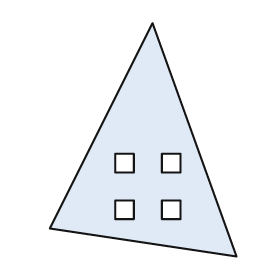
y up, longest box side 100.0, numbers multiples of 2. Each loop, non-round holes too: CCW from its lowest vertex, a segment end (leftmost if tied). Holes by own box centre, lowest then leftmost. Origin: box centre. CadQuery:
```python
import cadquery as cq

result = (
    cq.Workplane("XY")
    .moveTo(40.0, -50.0)
    .lineTo(4.0, 50.0)
    .lineTo(-40.0, -38.0)
    .close()
    .moveTo(-12.0, -34.0)
    .lineTo(-4.0, -34.0)
    .lineTo(-4.0, -26.0)
    .lineTo(-12.0, -26.0)
    .close()
    .moveTo(8.0, -34.0)
    .lineTo(16.0, -34.0)
    .lineTo(16.0, -26.0)
    .lineTo(8.0, -26.0)
    .close()
    .moveTo(-12.0, -14.0)
    .lineTo(-4.0, -14.0)
    .lineTo(-4.0, -6.0)
    .lineTo(-12.0, -6.0)
    .close()
    .moveTo(8.0, -14.0)
    .lineTo(16.0, -14.0)
    .lineTo(16.0, -6.0)
    .lineTo(8.0, -6.0)
    .close()
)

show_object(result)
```